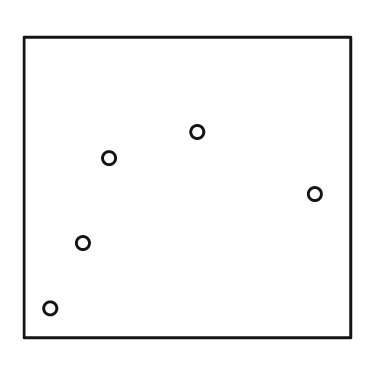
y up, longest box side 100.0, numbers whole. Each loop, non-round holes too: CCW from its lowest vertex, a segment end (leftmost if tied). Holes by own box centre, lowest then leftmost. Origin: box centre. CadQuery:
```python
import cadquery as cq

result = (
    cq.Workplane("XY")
    .moveTo(-50.0, -46.0)
    .lineTo(50.0, -46.0)
    .lineTo(50.0, 46.0)
    .lineTo(-50.0, 46.0)
    .close()
    .moveTo(-42.0, -37.0)
    .circle(2.0)
    .moveTo(-32.0, -17.0)
    .circle(2.0)
    .moveTo(39.0, -2.0)
    .circle(2.0)
    .moveTo(-24.0, 9.0)
    .circle(2.0)
    .moveTo(3.0, 17.0)
    .circle(2.0)
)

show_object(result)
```